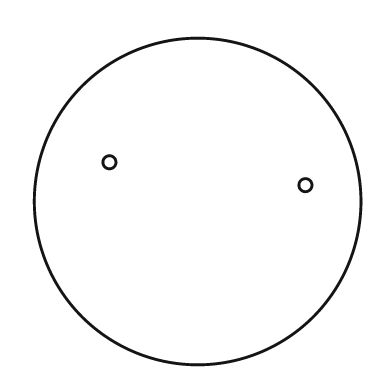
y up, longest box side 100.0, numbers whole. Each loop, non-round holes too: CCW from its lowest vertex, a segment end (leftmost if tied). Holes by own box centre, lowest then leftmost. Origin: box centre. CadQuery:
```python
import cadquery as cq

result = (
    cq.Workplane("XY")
    .moveTo(0.0, 0.0)
    .circle(50.0)
    .moveTo(33.0, 5.0)
    .circle(2.0)
    .moveTo(-27.0, 12.0)
    .circle(2.0)
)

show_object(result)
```